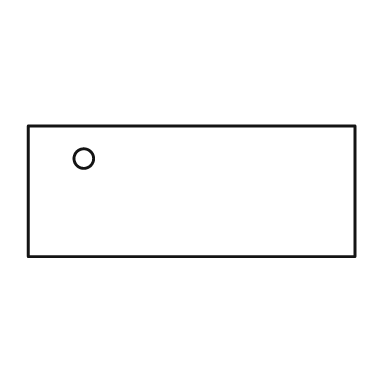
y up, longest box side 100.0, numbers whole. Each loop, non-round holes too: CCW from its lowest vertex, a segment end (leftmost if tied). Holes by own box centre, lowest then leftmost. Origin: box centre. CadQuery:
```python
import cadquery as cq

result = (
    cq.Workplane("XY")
    .moveTo(-50.0, -20.0)
    .lineTo(50.0, -20.0)
    .lineTo(50.0, 20.0)
    .lineTo(-50.0, 20.0)
    .close()
    .moveTo(-33.0, 10.0)
    .circle(3.0)
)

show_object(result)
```